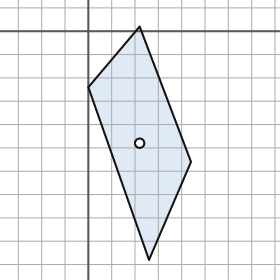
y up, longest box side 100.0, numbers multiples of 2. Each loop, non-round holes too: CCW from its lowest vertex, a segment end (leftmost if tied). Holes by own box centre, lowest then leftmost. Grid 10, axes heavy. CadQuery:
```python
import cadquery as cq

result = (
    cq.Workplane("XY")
    .moveTo(26.0, -98.0)
    .lineTo(44.0, -56.0)
    .lineTo(22.0, 2.0)
    .lineTo(0.0, -24.0)
    .close()
    .moveTo(22.0, -48.0)
    .circle(2.0)
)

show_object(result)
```